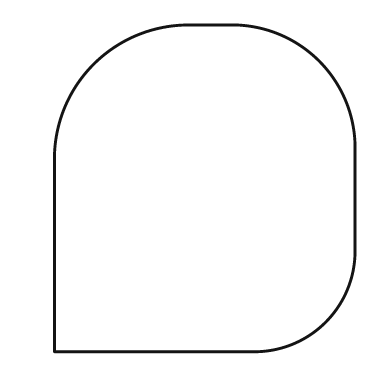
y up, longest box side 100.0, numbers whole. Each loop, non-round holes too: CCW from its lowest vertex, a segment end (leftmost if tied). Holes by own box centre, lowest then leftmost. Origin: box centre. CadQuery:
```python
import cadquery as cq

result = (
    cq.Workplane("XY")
    .moveTo(-46.0, -50.0)
    .lineTo(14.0, -50.0)
    .threePointArc((37.0, -41.0), (46.0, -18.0))
    .lineTo(46.0, 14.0)
    .threePointArc((35.0, 39.0), (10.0, 50.0))
    .lineTo(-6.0, 50.0)
    .threePointArc((-34.0, 38.0), (-46.0, 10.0))
    .close()
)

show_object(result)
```